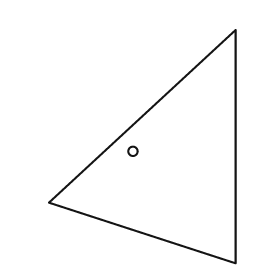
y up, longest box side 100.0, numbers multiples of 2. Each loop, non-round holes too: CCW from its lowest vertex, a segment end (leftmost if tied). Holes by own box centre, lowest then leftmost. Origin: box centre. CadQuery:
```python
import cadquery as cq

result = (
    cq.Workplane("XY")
    .moveTo(40.0, -50.0)
    .lineTo(40.0, 50.0)
    .lineTo(-40.0, -24.0)
    .close()
    .moveTo(-4.0, -2.0)
    .circle(2.0)
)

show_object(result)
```